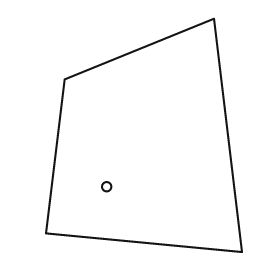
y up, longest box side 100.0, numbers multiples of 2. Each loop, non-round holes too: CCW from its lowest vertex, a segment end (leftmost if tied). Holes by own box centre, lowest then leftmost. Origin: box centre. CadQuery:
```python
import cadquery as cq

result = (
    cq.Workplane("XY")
    .moveTo(42.0, -50.0)
    .lineTo(30.0, 50.0)
    .lineTo(-34.0, 24.0)
    .lineTo(-42.0, -42.0)
    .close()
    .moveTo(-16.0, -22.0)
    .circle(2.0)
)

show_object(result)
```